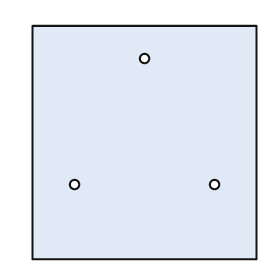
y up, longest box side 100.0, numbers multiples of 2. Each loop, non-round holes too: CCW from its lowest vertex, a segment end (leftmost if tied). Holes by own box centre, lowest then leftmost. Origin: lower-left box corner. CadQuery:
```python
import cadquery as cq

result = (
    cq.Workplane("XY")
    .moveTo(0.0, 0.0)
    .lineTo(96.0, 0.0)
    .lineTo(96.0, 100.0)
    .lineTo(0.0, 100.0)
    .close()
    .moveTo(18.0, 32.0)
    .circle(2.0)
    .moveTo(78.0, 32.0)
    .circle(2.0)
    .moveTo(48.0, 86.0)
    .circle(2.0)
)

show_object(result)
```